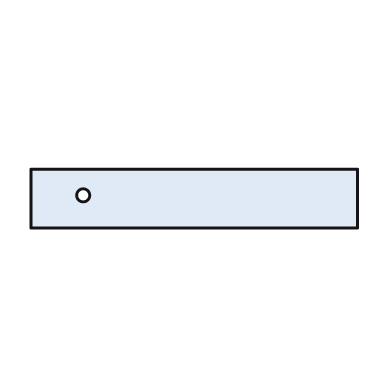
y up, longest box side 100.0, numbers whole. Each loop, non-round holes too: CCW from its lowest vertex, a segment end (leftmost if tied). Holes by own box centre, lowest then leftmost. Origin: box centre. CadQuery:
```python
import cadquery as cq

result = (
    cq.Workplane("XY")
    .moveTo(-50.0, -9.0)
    .lineTo(50.0, -9.0)
    .lineTo(50.0, 9.0)
    .lineTo(-50.0, 9.0)
    .close()
    .moveTo(-34.0, 1.0)
    .circle(2.0)
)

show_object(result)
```